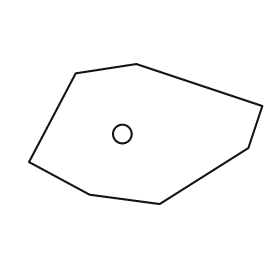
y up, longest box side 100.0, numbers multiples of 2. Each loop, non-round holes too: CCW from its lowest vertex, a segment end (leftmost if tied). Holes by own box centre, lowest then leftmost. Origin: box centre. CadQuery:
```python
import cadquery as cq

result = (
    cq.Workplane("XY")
    .moveTo(6.0, -30.0)
    .lineTo(44.0, -6.0)
    .lineTo(50.0, 12.0)
    .lineTo(-4.0, 30.0)
    .lineTo(-30.0, 26.0)
    .lineTo(-50.0, -12.0)
    .lineTo(-24.0, -26.0)
    .close()
    .moveTo(-10.0, 0.0)
    .circle(4.0)
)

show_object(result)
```